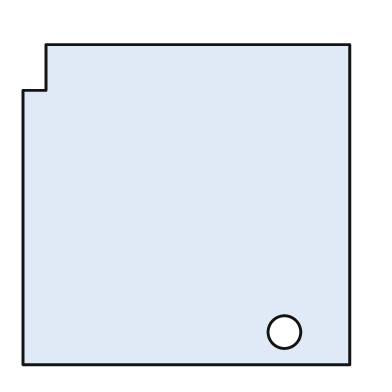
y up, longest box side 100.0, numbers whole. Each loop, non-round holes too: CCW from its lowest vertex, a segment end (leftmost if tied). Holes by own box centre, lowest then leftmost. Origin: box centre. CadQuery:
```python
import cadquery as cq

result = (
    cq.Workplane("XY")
    .moveTo(-50.0, -49.0)
    .lineTo(50.0, -49.0)
    .lineTo(50.0, 49.0)
    .lineTo(-43.0, 49.0)
    .lineTo(-43.0, 35.0)
    .lineTo(-50.0, 35.0)
    .close()
    .moveTo(30.0, -39.0)
    .circle(5.0)
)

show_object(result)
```